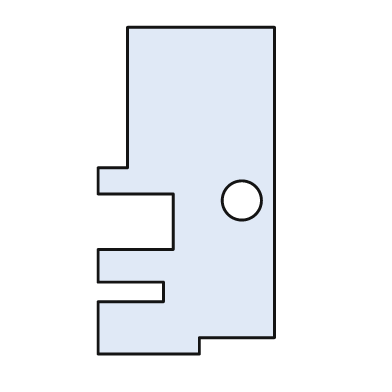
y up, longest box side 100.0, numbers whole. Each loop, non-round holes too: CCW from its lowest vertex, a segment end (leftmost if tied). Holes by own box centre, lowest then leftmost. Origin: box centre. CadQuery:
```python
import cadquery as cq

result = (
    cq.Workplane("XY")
    .moveTo(-27.0, -50.0)
    .lineTo(4.0, -50.0)
    .lineTo(4.0, -45.0)
    .lineTo(27.0, -45.0)
    .lineTo(27.0, 50.0)
    .lineTo(-18.0, 50.0)
    .lineTo(-18.0, 7.0)
    .lineTo(-27.0, 7.0)
    .lineTo(-27.0, -1.0)
    .lineTo(-4.0, -1.0)
    .lineTo(-4.0, -18.0)
    .lineTo(-27.0, -18.0)
    .lineTo(-27.0, -28.0)
    .lineTo(-7.0, -28.0)
    .lineTo(-7.0, -34.0)
    .lineTo(-27.0, -34.0)
    .close()
    .moveTo(17.0, -3.0)
    .circle(6.0)
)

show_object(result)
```